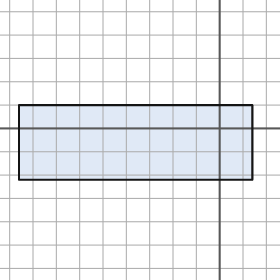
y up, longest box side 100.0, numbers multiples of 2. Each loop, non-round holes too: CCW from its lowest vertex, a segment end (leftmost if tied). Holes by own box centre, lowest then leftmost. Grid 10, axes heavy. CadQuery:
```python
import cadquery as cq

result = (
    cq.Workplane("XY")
    .moveTo(-86.0, -22.0)
    .lineTo(14.0, -22.0)
    .lineTo(14.0, 10.0)
    .lineTo(-86.0, 10.0)
    .close()
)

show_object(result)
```